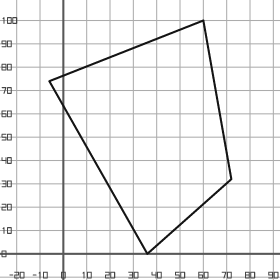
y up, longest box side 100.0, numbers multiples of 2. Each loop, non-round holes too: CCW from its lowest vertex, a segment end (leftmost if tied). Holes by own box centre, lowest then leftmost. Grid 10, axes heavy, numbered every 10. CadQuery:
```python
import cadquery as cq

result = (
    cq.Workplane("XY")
    .moveTo(36.0, 0.0)
    .lineTo(72.0, 32.0)
    .lineTo(60.0, 100.0)
    .lineTo(-6.0, 74.0)
    .close()
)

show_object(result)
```